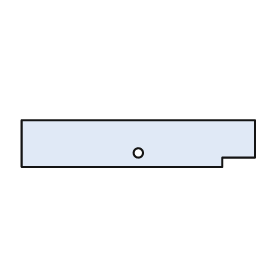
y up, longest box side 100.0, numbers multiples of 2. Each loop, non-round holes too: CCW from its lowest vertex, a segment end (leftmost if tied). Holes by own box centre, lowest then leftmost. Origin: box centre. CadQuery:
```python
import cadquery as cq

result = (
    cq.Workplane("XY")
    .moveTo(-50.0, -10.0)
    .lineTo(36.0, -10.0)
    .lineTo(36.0, -6.0)
    .lineTo(50.0, -6.0)
    .lineTo(50.0, 10.0)
    .lineTo(-50.0, 10.0)
    .close()
    .moveTo(0.0, -4.0)
    .circle(2.0)
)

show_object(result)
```